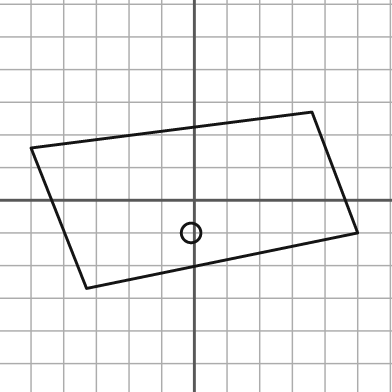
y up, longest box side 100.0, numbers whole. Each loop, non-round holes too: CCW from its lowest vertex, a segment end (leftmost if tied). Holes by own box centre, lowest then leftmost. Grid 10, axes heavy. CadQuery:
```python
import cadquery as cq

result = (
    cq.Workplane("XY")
    .moveTo(-33.0, -27.0)
    .lineTo(50.0, -10.0)
    .lineTo(36.0, 27.0)
    .lineTo(-50.0, 16.0)
    .close()
    .moveTo(-1.0, -10.0)
    .circle(3.0)
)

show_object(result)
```